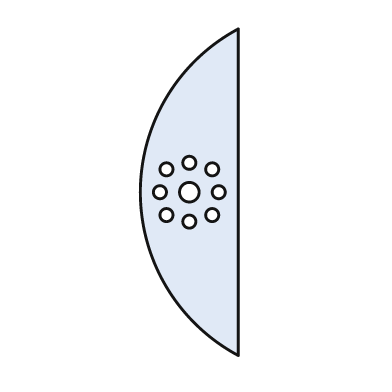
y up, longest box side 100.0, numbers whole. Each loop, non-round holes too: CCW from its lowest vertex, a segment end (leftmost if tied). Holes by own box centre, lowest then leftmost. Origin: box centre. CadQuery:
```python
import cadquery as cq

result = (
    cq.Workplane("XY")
    .moveTo(15.0, -50.0)
    .lineTo(15.0, 50.0)
    .threePointArc((-15.0, 0.0), (15.0, -50.0))
    .close()
    .moveTo(0.0, -9.0)
    .circle(2.0)
    .moveTo(-7.0, -7.0)
    .circle(2.0)
    .moveTo(7.0, -7.0)
    .circle(2.0)
    .moveTo(-9.0, 0.0)
    .circle(2.0)
    .moveTo(0.0, 0.0)
    .circle(3.0)
    .moveTo(9.0, 0.0)
    .circle(2.0)
    .moveTo(-7.0, 7.0)
    .circle(2.0)
    .moveTo(7.0, 7.0)
    .circle(2.0)
    .moveTo(0.0, 9.0)
    .circle(2.0)
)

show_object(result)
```